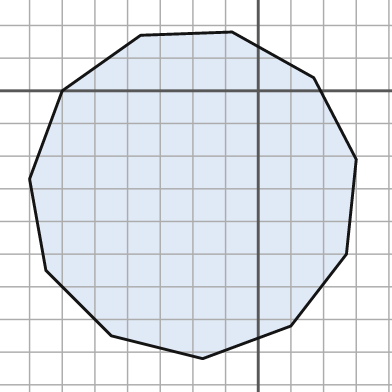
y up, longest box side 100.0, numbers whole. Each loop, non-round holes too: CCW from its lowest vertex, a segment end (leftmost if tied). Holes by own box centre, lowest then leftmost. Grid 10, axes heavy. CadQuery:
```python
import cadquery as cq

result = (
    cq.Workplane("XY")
    .moveTo(-17.0, -82.0)
    .lineTo(10.0, -72.0)
    .lineTo(27.0, -50.0)
    .lineTo(30.0, -21.0)
    .lineTo(17.0, 4.0)
    .lineTo(-8.0, 18.0)
    .lineTo(-36.0, 17.0)
    .lineTo(-60.0, 0.0)
    .lineTo(-70.0, -27.0)
    .lineTo(-65.0, -55.0)
    .lineTo(-45.0, -75.0)
    .close()
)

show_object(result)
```